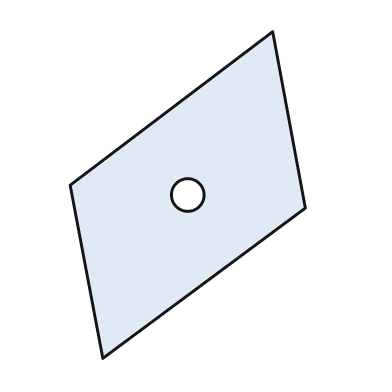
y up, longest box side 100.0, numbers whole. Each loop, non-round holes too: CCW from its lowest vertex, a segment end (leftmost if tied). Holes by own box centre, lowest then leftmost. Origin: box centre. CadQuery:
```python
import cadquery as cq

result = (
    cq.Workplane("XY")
    .moveTo(-26.0, -50.0)
    .lineTo(36.0, -4.0)
    .lineTo(26.0, 50.0)
    .lineTo(-36.0, 3.0)
    .close()
    .moveTo(0.0, 0.0)
    .circle(5.0)
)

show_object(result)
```